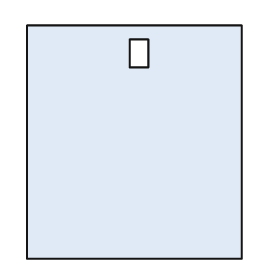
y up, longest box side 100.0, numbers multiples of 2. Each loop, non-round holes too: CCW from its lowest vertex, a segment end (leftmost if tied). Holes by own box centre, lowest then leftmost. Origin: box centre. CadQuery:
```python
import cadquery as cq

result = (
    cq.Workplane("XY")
    .moveTo(-46.0, -50.0)
    .lineTo(46.0, -50.0)
    .lineTo(46.0, 50.0)
    .lineTo(-46.0, 50.0)
    .close()
    .moveTo(-2.0, 32.0)
    .lineTo(6.0, 32.0)
    .lineTo(6.0, 44.0)
    .lineTo(-2.0, 44.0)
    .close()
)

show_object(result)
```